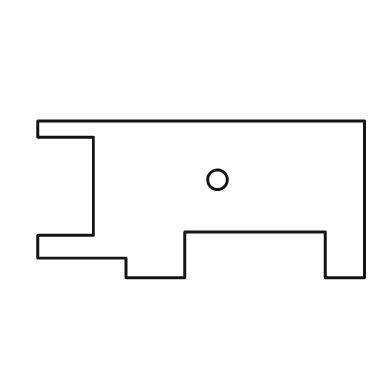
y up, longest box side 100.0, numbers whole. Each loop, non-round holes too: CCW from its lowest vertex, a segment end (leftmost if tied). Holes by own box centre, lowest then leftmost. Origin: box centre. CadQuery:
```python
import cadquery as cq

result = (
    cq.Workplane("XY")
    .moveTo(-23.0, -24.0)
    .lineTo(-5.0, -24.0)
    .lineTo(-5.0, -10.0)
    .lineTo(38.0, -10.0)
    .lineTo(38.0, -24.0)
    .lineTo(50.0, -24.0)
    .lineTo(50.0, 24.0)
    .lineTo(-50.0, 24.0)
    .lineTo(-50.0, 19.0)
    .lineTo(-33.0, 19.0)
    .lineTo(-33.0, -11.0)
    .lineTo(-50.0, -11.0)
    .lineTo(-50.0, -18.0)
    .lineTo(-23.0, -18.0)
    .close()
    .moveTo(5.0, 6.0)
    .circle(3.0)
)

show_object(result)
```